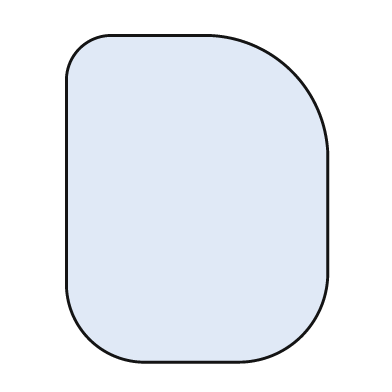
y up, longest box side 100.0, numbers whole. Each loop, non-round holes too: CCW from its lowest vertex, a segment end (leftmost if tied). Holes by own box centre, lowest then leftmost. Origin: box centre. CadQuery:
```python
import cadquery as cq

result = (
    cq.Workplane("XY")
    .moveTo(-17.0, -50.0)
    .lineTo(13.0, -50.0)
    .threePointArc((32.0, -42.0), (40.0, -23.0))
    .lineTo(40.0, 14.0)
    .threePointArc((29.0, 39.0), (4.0, 50.0))
    .lineTo(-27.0, 50.0)
    .threePointArc((-36.0, 46.0), (-40.0, 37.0))
    .lineTo(-40.0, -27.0)
    .threePointArc((-33.0, -43.0), (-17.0, -50.0))
    .close()
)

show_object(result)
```